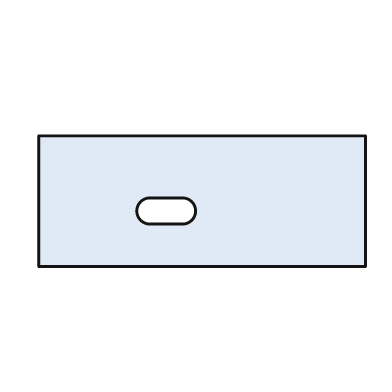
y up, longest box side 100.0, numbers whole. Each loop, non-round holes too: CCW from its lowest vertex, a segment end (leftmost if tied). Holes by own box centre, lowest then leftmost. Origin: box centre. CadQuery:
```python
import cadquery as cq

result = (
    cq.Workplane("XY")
    .moveTo(-50.0, -20.0)
    .lineTo(50.0, -20.0)
    .lineTo(50.0, 20.0)
    .lineTo(-50.0, 20.0)
    .close()
    .moveTo(-16.0, -7.0)
    .lineTo(-6.0, -7.0)
    .threePointArc((-2.0, -3.0), (-6.0, 1.0))
    .lineTo(-16.0, 1.0)
    .threePointArc((-20.0, -3.0), (-16.0, -7.0))
    .close()
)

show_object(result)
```